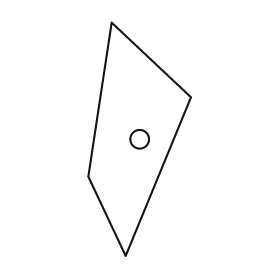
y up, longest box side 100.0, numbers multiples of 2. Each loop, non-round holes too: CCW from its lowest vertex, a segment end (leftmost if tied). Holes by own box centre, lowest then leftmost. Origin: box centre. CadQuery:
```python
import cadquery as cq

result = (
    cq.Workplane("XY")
    .moveTo(-6.0, -50.0)
    .lineTo(22.0, 18.0)
    .lineTo(-12.0, 50.0)
    .lineTo(-22.0, -16.0)
    .close()
    .moveTo(0.0, 0.0)
    .circle(4.0)
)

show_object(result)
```